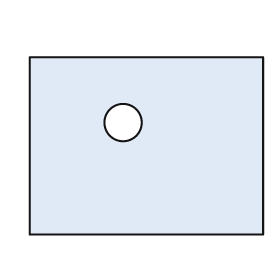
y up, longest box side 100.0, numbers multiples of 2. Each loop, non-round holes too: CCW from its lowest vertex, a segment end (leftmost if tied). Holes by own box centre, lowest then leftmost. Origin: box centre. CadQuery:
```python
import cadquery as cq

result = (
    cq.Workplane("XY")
    .moveTo(-50.0, -38.0)
    .lineTo(50.0, -38.0)
    .lineTo(50.0, 38.0)
    .lineTo(-50.0, 38.0)
    .close()
    .moveTo(-10.0, 10.0)
    .circle(8.0)
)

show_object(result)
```